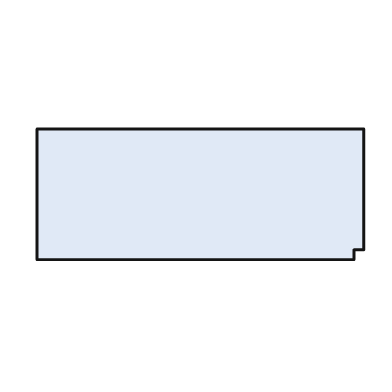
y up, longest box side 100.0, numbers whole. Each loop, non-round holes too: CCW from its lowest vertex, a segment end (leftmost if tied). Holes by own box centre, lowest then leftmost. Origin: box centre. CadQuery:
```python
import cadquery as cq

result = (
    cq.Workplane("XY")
    .moveTo(-50.0, -20.0)
    .lineTo(47.0, -20.0)
    .lineTo(47.0, -17.0)
    .lineTo(50.0, -17.0)
    .lineTo(50.0, 20.0)
    .lineTo(-50.0, 20.0)
    .close()
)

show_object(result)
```